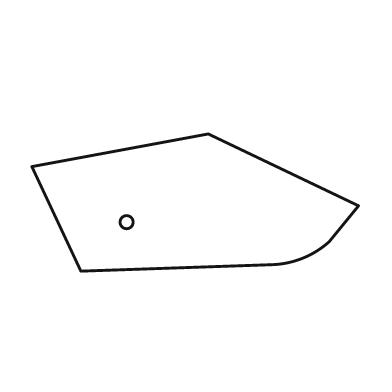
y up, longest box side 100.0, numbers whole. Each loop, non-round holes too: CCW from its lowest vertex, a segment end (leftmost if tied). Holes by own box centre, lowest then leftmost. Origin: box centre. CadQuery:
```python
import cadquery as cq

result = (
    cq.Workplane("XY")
    .moveTo(-35.0, -21.0)
    .lineTo(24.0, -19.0)
    .threePointArc((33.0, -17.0), (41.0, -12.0))
    .lineTo(50.0, -1.0)
    .lineTo(4.0, 21.0)
    .lineTo(-50.0, 11.0)
    .close()
    .moveTo(-21.0, -6.0)
    .circle(2.0)
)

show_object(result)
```